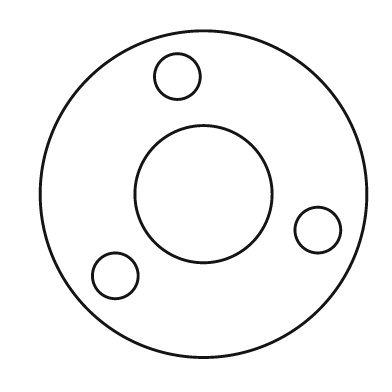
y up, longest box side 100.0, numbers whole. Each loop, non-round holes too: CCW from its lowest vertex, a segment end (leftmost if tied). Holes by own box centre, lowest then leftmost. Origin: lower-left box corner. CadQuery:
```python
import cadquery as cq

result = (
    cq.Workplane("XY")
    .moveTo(50.0, 50.0)
    .circle(50.0)
    .moveTo(23.0, 25.0)
    .circle(7.0)
    .moveTo(85.0, 39.0)
    .circle(7.0)
    .moveTo(50.0, 50.0)
    .circle(21.0)
    .moveTo(42.0, 86.0)
    .circle(7.0)
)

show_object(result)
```